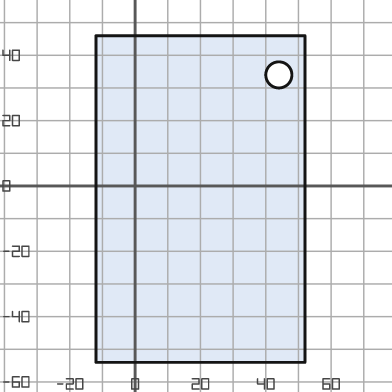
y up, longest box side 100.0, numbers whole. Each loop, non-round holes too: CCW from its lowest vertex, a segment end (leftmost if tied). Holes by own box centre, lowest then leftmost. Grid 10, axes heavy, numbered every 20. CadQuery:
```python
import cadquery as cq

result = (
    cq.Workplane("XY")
    .moveTo(-12.0, -54.0)
    .lineTo(52.0, -54.0)
    .lineTo(52.0, 46.0)
    .lineTo(-12.0, 46.0)
    .close()
    .moveTo(44.0, 34.0)
    .circle(4.0)
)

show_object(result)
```